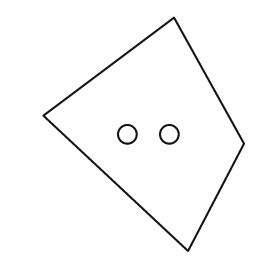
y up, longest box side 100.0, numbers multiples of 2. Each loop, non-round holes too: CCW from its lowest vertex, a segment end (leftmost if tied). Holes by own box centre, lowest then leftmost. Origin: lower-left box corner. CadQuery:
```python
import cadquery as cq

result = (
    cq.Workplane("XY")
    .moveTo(62.0, 0.0)
    .lineTo(86.0, 46.0)
    .lineTo(56.0, 100.0)
    .lineTo(0.0, 58.0)
    .close()
    .moveTo(36.0, 50.0)
    .circle(4.0)
    .moveTo(54.0, 50.0)
    .circle(4.0)
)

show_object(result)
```